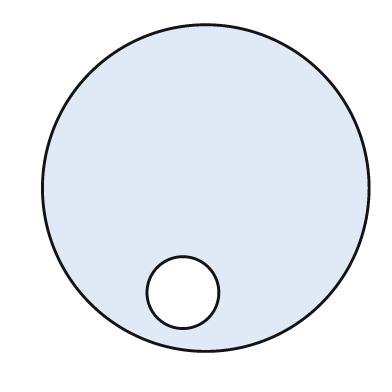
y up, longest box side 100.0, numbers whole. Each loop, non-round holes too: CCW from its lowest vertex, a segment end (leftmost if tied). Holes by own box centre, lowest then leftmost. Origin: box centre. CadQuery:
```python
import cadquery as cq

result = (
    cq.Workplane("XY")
    .moveTo(0.0, 0.0)
    .circle(50.0)
    .moveTo(-7.0, -32.0)
    .circle(11.0)
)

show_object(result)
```